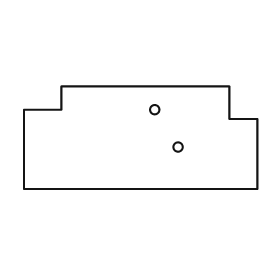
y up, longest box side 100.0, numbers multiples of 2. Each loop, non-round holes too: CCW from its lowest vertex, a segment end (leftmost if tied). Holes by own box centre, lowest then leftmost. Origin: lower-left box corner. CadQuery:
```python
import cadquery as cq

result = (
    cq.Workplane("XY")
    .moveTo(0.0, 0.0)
    .lineTo(100.0, 0.0)
    .lineTo(100.0, 30.0)
    .lineTo(88.0, 30.0)
    .lineTo(88.0, 44.0)
    .lineTo(16.0, 44.0)
    .lineTo(16.0, 34.0)
    .lineTo(0.0, 34.0)
    .close()
    .moveTo(66.0, 18.0)
    .circle(2.0)
    .moveTo(56.0, 34.0)
    .circle(2.0)
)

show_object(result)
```